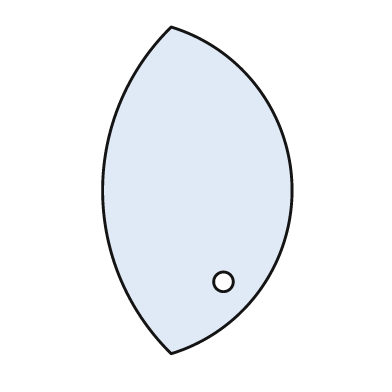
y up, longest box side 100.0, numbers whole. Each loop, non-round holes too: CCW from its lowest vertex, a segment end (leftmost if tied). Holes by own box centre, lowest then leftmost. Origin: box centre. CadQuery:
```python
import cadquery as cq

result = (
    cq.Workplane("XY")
    .moveTo(-8.0, -50.0)
    .threePointArc((29.0, 0.0), (-8.0, 50.0))
    .threePointArc((-29.0, 0.0), (-8.0, -50.0))
    .close()
    .moveTo(8.0, -28.0)
    .circle(3.0)
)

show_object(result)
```